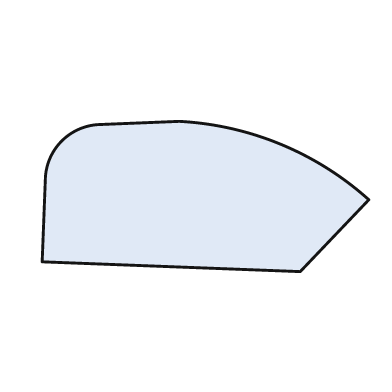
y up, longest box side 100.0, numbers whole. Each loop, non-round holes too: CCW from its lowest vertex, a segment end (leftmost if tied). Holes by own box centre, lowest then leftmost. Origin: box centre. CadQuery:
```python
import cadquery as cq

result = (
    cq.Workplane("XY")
    .moveTo(29.0, -23.0)
    .lineTo(50.0, -1.0)
    .threePointArc((23.0, 16.0), (-8.0, 23.0))
    .lineTo(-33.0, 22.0)
    .threePointArc((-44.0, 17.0), (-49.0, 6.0))
    .lineTo(-50.0, -20.0)
    .close()
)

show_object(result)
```